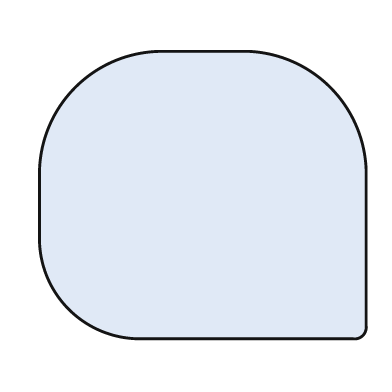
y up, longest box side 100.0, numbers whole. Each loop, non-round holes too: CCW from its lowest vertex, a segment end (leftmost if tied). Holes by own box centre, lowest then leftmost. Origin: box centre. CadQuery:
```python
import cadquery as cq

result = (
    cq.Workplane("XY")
    .moveTo(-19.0, -44.0)
    .lineTo(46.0, -44.0)
    .threePointArc((49.0, -43.0), (50.0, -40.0))
    .lineTo(50.0, 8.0)
    .threePointArc((39.0, 33.0), (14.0, 44.0))
    .lineTo(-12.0, 44.0)
    .threePointArc((-39.0, 33.0), (-50.0, 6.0))
    .lineTo(-50.0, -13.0)
    .threePointArc((-41.0, -35.0), (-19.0, -44.0))
    .close()
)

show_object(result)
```